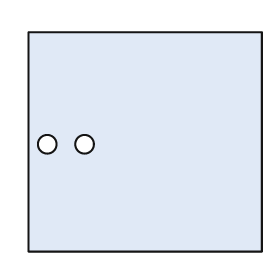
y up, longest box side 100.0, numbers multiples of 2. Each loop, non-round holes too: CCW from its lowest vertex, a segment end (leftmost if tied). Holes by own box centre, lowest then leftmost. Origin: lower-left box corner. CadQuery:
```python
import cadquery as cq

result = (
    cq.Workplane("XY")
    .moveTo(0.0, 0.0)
    .lineTo(100.0, 0.0)
    .lineTo(100.0, 94.0)
    .lineTo(0.0, 94.0)
    .close()
    .moveTo(8.0, 46.0)
    .circle(4.0)
    .moveTo(24.0, 46.0)
    .circle(4.0)
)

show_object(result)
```